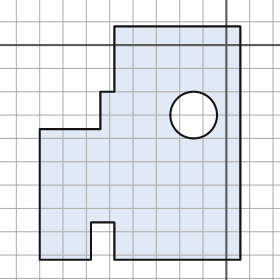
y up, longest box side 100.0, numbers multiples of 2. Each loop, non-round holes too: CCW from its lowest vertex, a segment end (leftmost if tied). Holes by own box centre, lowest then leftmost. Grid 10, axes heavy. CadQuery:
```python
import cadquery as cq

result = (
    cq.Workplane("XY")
    .moveTo(-80.0, -92.0)
    .lineTo(-58.0, -92.0)
    .lineTo(-58.0, -76.0)
    .lineTo(-48.0, -76.0)
    .lineTo(-48.0, -92.0)
    .lineTo(6.0, -92.0)
    .lineTo(6.0, 8.0)
    .lineTo(-48.0, 8.0)
    .lineTo(-48.0, -20.0)
    .lineTo(-54.0, -20.0)
    .lineTo(-54.0, -36.0)
    .lineTo(-80.0, -36.0)
    .close()
    .moveTo(-14.0, -30.0)
    .circle(10.0)
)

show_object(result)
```